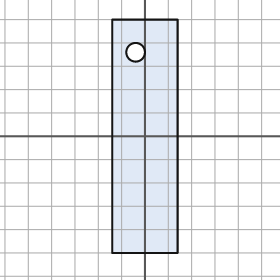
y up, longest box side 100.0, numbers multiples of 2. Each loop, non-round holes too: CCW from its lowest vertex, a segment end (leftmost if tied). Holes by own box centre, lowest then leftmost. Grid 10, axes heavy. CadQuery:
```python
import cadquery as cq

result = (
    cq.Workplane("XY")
    .moveTo(-14.0, -50.0)
    .lineTo(14.0, -50.0)
    .lineTo(14.0, 50.0)
    .lineTo(-14.0, 50.0)
    .close()
    .moveTo(-4.0, 36.0)
    .circle(4.0)
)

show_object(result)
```